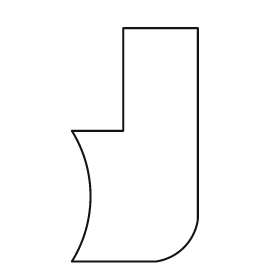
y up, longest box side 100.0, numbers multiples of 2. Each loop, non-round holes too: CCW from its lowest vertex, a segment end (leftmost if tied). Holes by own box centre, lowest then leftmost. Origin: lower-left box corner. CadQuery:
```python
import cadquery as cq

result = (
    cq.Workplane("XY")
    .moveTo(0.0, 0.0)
    .lineTo(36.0, 0.0)
    .threePointArc((48.0, 6.0), (54.0, 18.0))
    .lineTo(54.0, 100.0)
    .lineTo(22.0, 100.0)
    .lineTo(22.0, 56.0)
    .lineTo(0.0, 56.0)
    .threePointArc((8.0, 28.0), (0.0, 0.0))
    .close()
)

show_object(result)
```